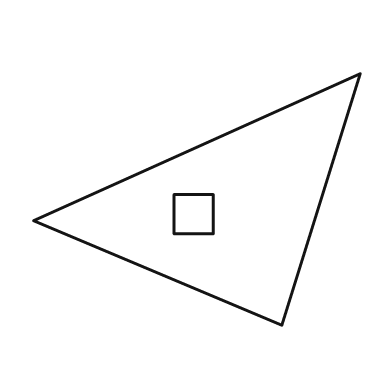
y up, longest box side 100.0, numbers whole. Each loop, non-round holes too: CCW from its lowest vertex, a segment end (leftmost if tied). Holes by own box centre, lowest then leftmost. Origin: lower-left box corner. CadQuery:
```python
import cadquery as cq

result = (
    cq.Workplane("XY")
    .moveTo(76.0, 0.0)
    .lineTo(100.0, 77.0)
    .lineTo(0.0, 32.0)
    .close()
    .moveTo(43.0, 28.0)
    .lineTo(55.0, 28.0)
    .lineTo(55.0, 40.0)
    .lineTo(43.0, 40.0)
    .close()
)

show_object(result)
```